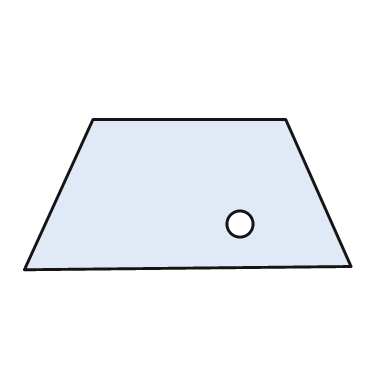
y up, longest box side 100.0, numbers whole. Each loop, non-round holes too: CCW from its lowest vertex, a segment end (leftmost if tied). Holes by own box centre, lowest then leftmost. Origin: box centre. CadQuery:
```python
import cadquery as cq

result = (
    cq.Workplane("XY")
    .moveTo(-50.0, -23.0)
    .lineTo(50.0, -22.0)
    .lineTo(30.0, 23.0)
    .lineTo(-29.0, 23.0)
    .close()
    .moveTo(16.0, -9.0)
    .circle(4.0)
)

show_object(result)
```